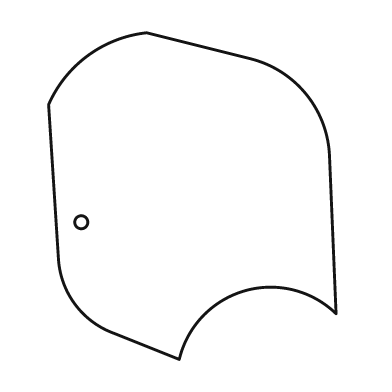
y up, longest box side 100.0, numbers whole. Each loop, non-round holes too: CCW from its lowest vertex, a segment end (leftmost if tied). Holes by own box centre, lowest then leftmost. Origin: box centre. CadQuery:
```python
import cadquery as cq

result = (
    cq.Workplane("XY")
    .moveTo(-4.0, -50.0)
    .threePointArc((16.0, -29.0), (44.0, -36.0))
    .lineTo(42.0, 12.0)
    .threePointArc((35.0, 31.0), (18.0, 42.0))
    .lineTo(-14.0, 50.0)
    .threePointArc((-32.0, 43.0), (-44.0, 28.0))
    .lineTo(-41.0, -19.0)
    .threePointArc((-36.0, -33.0), (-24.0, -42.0))
    .close()
    .moveTo(-34.0, -8.0)
    .circle(2.0)
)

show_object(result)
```